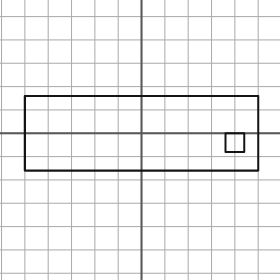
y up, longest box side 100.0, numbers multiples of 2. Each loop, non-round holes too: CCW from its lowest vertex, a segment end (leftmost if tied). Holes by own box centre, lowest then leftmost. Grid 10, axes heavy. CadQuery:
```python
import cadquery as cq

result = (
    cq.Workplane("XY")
    .moveTo(-50.0, -16.0)
    .lineTo(50.0, -16.0)
    .lineTo(50.0, 16.0)
    .lineTo(-50.0, 16.0)
    .close()
    .moveTo(36.0, -8.0)
    .lineTo(44.0, -8.0)
    .lineTo(44.0, 0.0)
    .lineTo(36.0, 0.0)
    .close()
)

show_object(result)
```